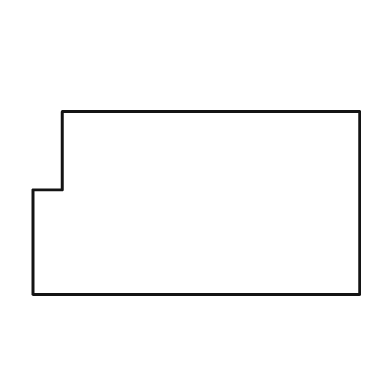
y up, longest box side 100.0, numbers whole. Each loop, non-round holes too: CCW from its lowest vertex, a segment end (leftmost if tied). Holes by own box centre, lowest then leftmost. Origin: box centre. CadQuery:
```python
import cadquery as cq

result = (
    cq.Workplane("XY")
    .moveTo(-50.0, -28.0)
    .lineTo(50.0, -28.0)
    .lineTo(50.0, 28.0)
    .lineTo(-41.0, 28.0)
    .lineTo(-41.0, 4.0)
    .lineTo(-50.0, 4.0)
    .close()
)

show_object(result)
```